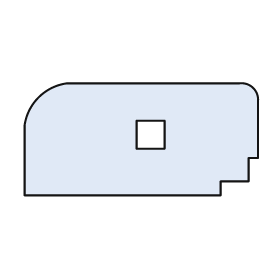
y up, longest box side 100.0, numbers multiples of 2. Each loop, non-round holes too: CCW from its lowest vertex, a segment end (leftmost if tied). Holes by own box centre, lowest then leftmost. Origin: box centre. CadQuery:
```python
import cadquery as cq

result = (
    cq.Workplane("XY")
    .moveTo(-50.0, -24.0)
    .lineTo(34.0, -24.0)
    .lineTo(34.0, -18.0)
    .lineTo(46.0, -18.0)
    .lineTo(46.0, -8.0)
    .lineTo(50.0, -8.0)
    .lineTo(50.0, 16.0)
    .threePointArc((48.0, 22.0), (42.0, 24.0))
    .lineTo(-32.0, 24.0)
    .threePointArc((-44.0, 18.0), (-50.0, 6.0))
    .close()
    .moveTo(-2.0, -4.0)
    .lineTo(10.0, -4.0)
    .lineTo(10.0, 8.0)
    .lineTo(-2.0, 8.0)
    .close()
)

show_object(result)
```